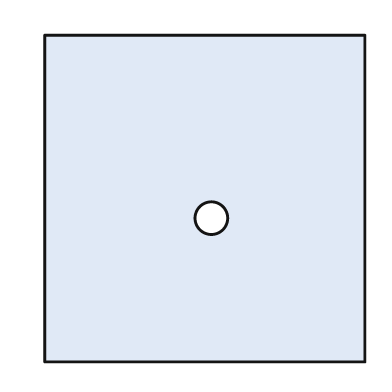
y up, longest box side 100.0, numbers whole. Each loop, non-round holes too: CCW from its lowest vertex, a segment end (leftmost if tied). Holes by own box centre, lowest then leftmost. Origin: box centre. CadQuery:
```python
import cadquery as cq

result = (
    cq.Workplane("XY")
    .moveTo(-49.0, -50.0)
    .lineTo(49.0, -50.0)
    .lineTo(49.0, 50.0)
    .lineTo(-49.0, 50.0)
    .close()
    .moveTo(2.0, -6.0)
    .circle(5.0)
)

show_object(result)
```